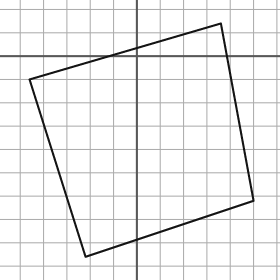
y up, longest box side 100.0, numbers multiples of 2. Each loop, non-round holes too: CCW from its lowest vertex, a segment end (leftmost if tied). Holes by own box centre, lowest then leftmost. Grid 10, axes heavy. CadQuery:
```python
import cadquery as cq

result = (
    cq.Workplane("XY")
    .moveTo(-22.0, -86.0)
    .lineTo(50.0, -62.0)
    .lineTo(36.0, 14.0)
    .lineTo(-46.0, -10.0)
    .close()
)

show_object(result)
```